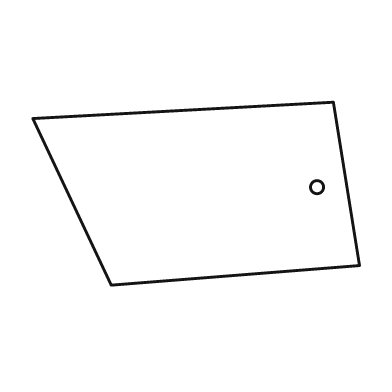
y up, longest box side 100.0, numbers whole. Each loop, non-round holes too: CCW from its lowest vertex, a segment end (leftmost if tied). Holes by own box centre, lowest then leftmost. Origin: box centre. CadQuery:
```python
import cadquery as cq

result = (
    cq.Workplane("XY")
    .moveTo(-26.0, -28.0)
    .lineTo(50.0, -22.0)
    .lineTo(42.0, 28.0)
    .lineTo(-50.0, 23.0)
    .close()
    .moveTo(37.0, 2.0)
    .circle(2.0)
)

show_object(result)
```